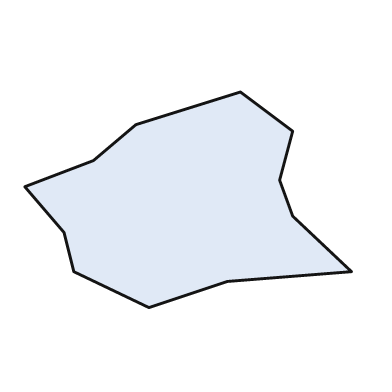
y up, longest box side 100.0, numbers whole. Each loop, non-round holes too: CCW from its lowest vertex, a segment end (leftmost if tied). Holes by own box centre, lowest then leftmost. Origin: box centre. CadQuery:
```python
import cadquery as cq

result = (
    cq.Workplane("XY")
    .moveTo(-12.0, -33.0)
    .lineTo(12.0, -25.0)
    .lineTo(50.0, -22.0)
    .lineTo(32.0, -5.0)
    .lineTo(28.0, 6.0)
    .lineTo(32.0, 21.0)
    .lineTo(16.0, 33.0)
    .lineTo(-16.0, 23.0)
    .lineTo(-29.0, 12.0)
    .lineTo(-50.0, 4.0)
    .lineTo(-38.0, -10.0)
    .lineTo(-35.0, -22.0)
    .close()
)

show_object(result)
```